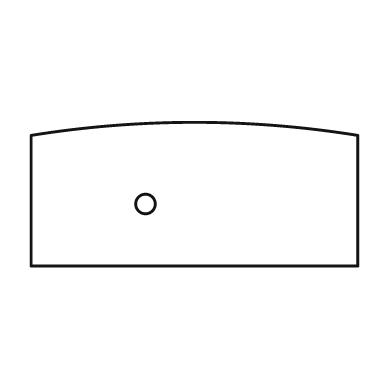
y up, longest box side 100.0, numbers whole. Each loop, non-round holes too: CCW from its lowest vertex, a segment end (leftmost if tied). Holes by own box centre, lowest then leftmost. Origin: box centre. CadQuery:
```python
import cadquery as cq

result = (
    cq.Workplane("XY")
    .moveTo(-50.0, -22.0)
    .lineTo(50.0, -22.0)
    .lineTo(50.0, 18.0)
    .threePointArc((0.0, 22.0), (-50.0, 18.0))
    .close()
    .moveTo(-15.0, -3.0)
    .circle(3.0)
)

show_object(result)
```